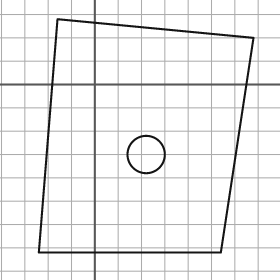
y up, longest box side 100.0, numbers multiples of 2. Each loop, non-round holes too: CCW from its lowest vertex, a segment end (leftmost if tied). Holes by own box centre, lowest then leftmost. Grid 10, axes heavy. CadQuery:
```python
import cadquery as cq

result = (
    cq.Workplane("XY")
    .moveTo(-24.0, -72.0)
    .lineTo(54.0, -72.0)
    .lineTo(68.0, 20.0)
    .lineTo(-16.0, 28.0)
    .close()
    .moveTo(22.0, -30.0)
    .circle(8.0)
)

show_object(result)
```